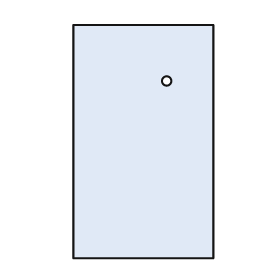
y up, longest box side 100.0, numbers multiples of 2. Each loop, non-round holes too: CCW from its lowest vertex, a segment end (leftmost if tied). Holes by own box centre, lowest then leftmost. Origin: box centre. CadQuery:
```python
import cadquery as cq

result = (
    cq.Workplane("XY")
    .moveTo(-30.0, -50.0)
    .lineTo(30.0, -50.0)
    .lineTo(30.0, 50.0)
    .lineTo(-30.0, 50.0)
    .close()
    .moveTo(10.0, 26.0)
    .circle(2.0)
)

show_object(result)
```